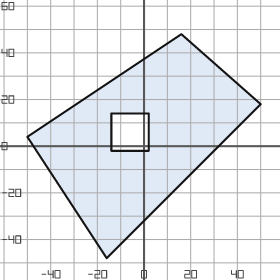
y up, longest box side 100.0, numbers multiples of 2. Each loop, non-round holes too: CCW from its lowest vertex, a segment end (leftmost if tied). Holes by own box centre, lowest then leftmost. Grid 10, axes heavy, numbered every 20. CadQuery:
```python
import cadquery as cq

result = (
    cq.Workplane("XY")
    .moveTo(-16.0, -48.0)
    .lineTo(50.0, 18.0)
    .lineTo(16.0, 48.0)
    .lineTo(-50.0, 4.0)
    .close()
    .moveTo(-14.0, -2.0)
    .lineTo(2.0, -2.0)
    .lineTo(2.0, 14.0)
    .lineTo(-14.0, 14.0)
    .close()
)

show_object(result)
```